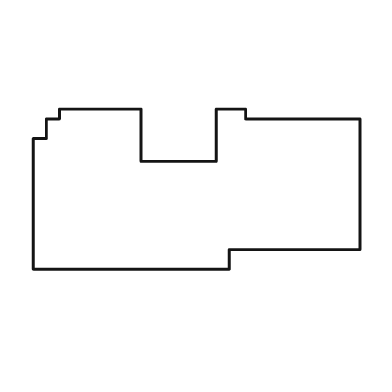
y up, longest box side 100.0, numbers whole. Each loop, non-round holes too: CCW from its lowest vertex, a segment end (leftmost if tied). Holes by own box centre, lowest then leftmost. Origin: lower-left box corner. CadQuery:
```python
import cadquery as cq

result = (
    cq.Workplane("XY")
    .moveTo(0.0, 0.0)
    .lineTo(60.0, 0.0)
    .lineTo(60.0, 6.0)
    .lineTo(100.0, 6.0)
    .lineTo(100.0, 46.0)
    .lineTo(65.0, 46.0)
    .lineTo(65.0, 49.0)
    .lineTo(56.0, 49.0)
    .lineTo(56.0, 33.0)
    .lineTo(33.0, 33.0)
    .lineTo(33.0, 49.0)
    .lineTo(8.0, 49.0)
    .lineTo(8.0, 46.0)
    .lineTo(4.0, 46.0)
    .lineTo(4.0, 40.0)
    .lineTo(0.0, 40.0)
    .close()
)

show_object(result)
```